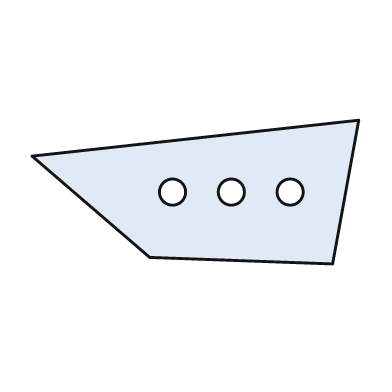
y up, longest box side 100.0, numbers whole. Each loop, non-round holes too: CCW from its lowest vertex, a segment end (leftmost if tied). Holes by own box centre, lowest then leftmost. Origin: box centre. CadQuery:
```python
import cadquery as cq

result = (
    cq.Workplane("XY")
    .moveTo(42.0, -22.0)
    .lineTo(50.0, 22.0)
    .lineTo(-50.0, 11.0)
    .lineTo(-14.0, -20.0)
    .close()
    .moveTo(-7.0, 0.0)
    .circle(4.0)
    .moveTo(11.0, 0.0)
    .circle(4.0)
    .moveTo(29.0, 0.0)
    .circle(4.0)
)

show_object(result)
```